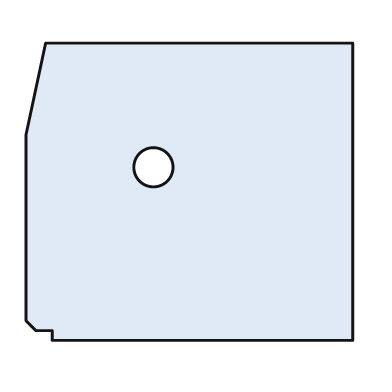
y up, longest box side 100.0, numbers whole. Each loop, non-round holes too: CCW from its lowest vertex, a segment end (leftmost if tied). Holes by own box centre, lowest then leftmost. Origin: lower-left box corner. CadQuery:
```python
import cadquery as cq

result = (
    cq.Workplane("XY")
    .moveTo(8.0, 0.0)
    .lineTo(100.0, 0.0)
    .lineTo(100.0, 91.0)
    .lineTo(6.0, 91.0)
    .lineTo(0.0, 63.0)
    .lineTo(0.0, 6.0)
    .lineTo(3.0, 3.0)
    .lineTo(8.0, 3.0)
    .close()
    .moveTo(39.0, 53.0)
    .circle(6.0)
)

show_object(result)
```